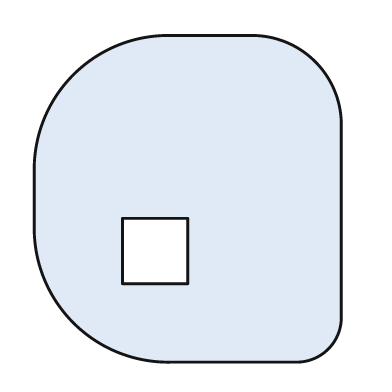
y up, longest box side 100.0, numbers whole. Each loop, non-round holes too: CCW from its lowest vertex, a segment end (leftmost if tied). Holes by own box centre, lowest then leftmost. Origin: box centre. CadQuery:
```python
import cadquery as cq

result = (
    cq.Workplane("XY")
    .moveTo(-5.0, -50.0)
    .lineTo(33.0, -50.0)
    .threePointArc((43.0, -46.0), (47.0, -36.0))
    .lineTo(47.0, 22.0)
    .threePointArc((39.0, 42.0), (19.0, 50.0))
    .lineTo(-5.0, 50.0)
    .threePointArc((-35.0, 38.0), (-47.0, 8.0))
    .lineTo(-47.0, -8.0)
    .threePointArc((-35.0, -38.0), (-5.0, -50.0))
    .close()
    .moveTo(-20.0, -26.0)
    .lineTo(0.0, -26.0)
    .lineTo(0.0, -6.0)
    .lineTo(-20.0, -6.0)
    .close()
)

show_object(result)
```